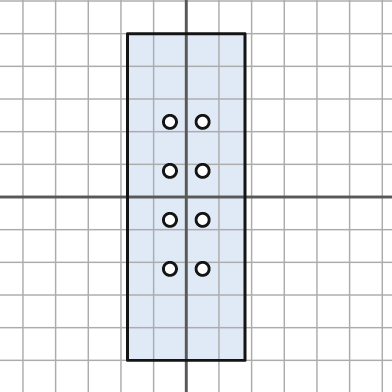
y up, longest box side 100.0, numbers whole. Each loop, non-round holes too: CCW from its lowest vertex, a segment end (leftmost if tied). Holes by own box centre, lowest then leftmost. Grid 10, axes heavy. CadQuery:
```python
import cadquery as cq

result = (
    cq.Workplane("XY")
    .moveTo(-18.0, -50.0)
    .lineTo(18.0, -50.0)
    .lineTo(18.0, 50.0)
    .lineTo(-18.0, 50.0)
    .close()
    .moveTo(-5.0, -22.0)
    .circle(2.0)
    .moveTo(5.0, -22.0)
    .circle(2.0)
    .moveTo(-5.0, -7.0)
    .circle(2.0)
    .moveTo(5.0, -7.0)
    .circle(2.0)
    .moveTo(-5.0, 8.0)
    .circle(2.0)
    .moveTo(5.0, 8.0)
    .circle(2.0)
    .moveTo(-5.0, 23.0)
    .circle(2.0)
    .moveTo(5.0, 23.0)
    .circle(2.0)
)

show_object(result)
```